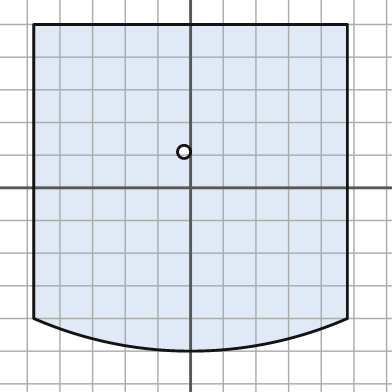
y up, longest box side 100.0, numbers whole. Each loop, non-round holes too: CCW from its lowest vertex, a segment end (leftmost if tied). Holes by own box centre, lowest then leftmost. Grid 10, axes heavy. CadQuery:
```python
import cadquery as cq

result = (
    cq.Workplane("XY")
    .moveTo(-48.0, -40.0)
    .threePointArc((0.0, -50.0), (48.0, -40.0))
    .lineTo(48.0, 50.0)
    .lineTo(-48.0, 50.0)
    .close()
    .moveTo(-2.0, 11.0)
    .circle(2.0)
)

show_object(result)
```